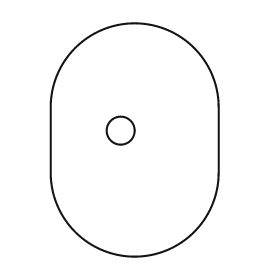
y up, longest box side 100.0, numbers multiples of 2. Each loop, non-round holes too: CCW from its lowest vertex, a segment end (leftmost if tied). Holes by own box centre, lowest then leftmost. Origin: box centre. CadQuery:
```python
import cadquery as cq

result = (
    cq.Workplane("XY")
    .moveTo(-36.0, -14.0)
    .threePointArc((0.0, -50.0), (36.0, -14.0))
    .lineTo(36.0, 14.0)
    .threePointArc((0.0, 50.0), (-36.0, 14.0))
    .close()
    .moveTo(-6.0, 4.0)
    .circle(6.0)
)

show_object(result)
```